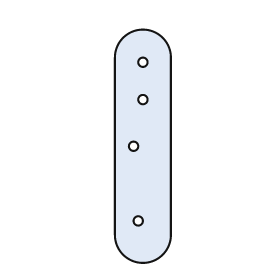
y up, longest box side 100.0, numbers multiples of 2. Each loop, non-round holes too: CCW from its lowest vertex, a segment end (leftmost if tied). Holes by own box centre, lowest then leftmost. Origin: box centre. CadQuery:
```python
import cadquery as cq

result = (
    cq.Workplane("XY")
    .moveTo(-12.0, -38.0)
    .threePointArc((0.0, -50.0), (12.0, -38.0))
    .lineTo(12.0, 38.0)
    .threePointArc((0.0, 50.0), (-12.0, 38.0))
    .close()
    .moveTo(-2.0, -32.0)
    .circle(2.0)
    .moveTo(-4.0, 0.0)
    .circle(2.0)
    .moveTo(0.0, 20.0)
    .circle(2.0)
    .moveTo(0.0, 36.0)
    .circle(2.0)
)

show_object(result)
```